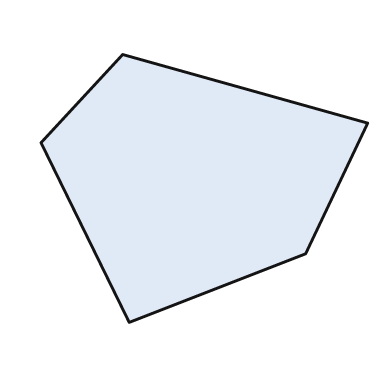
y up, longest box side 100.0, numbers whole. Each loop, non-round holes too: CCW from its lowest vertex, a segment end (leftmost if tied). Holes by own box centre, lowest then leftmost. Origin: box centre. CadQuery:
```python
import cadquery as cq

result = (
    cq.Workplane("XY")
    .moveTo(-23.0, -41.0)
    .lineTo(31.0, -20.0)
    .lineTo(50.0, 20.0)
    .lineTo(-25.0, 41.0)
    .lineTo(-50.0, 14.0)
    .close()
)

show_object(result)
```